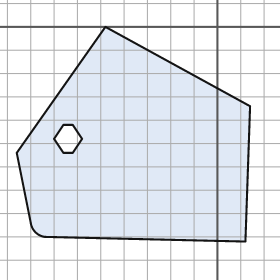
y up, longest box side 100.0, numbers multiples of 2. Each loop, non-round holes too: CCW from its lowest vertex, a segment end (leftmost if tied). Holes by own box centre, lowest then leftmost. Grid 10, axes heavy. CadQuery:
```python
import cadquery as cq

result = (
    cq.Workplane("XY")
    .moveTo(12.0, -92.0)
    .lineTo(14.0, -34.0)
    .lineTo(-48.0, 0.0)
    .lineTo(-86.0, -54.0)
    .lineTo(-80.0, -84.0)
    .threePointArc((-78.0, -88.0), (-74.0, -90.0))
    .close()
    .moveTo(-66.0, -54.0)
    .lineTo(-62.0, -54.0)
    .lineTo(-58.0, -48.0)
    .lineTo(-62.0, -42.0)
    .lineTo(-66.0, -42.0)
    .lineTo(-70.0, -48.0)
    .close()
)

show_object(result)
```